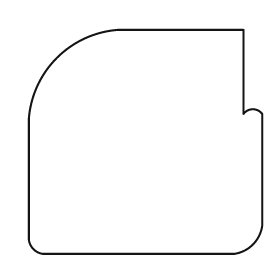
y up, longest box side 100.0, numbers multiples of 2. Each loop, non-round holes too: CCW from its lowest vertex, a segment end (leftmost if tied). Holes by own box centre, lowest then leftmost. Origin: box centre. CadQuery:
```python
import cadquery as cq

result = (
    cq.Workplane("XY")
    .moveTo(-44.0, -48.0)
    .lineTo(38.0, -48.0)
    .threePointArc((46.0, -44.0), (50.0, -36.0))
    .lineTo(50.0, 12.0)
    .threePointArc((46.0, 14.0), (42.0, 12.0))
    .lineTo(42.0, 48.0)
    .lineTo(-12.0, 48.0)
    .threePointArc((-38.0, 36.0), (-50.0, 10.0))
    .lineTo(-50.0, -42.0)
    .threePointArc((-48.0, -46.0), (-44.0, -48.0))
    .close()
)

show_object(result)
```